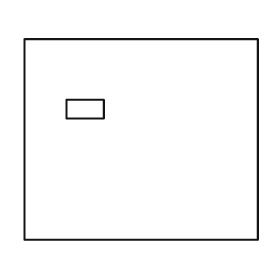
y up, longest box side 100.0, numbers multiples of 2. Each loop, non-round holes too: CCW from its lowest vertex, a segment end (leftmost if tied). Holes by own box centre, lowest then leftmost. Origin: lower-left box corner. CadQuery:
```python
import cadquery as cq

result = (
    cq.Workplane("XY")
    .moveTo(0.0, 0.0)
    .lineTo(100.0, 0.0)
    .lineTo(100.0, 86.0)
    .lineTo(0.0, 86.0)
    .close()
    .moveTo(18.0, 52.0)
    .lineTo(34.0, 52.0)
    .lineTo(34.0, 60.0)
    .lineTo(18.0, 60.0)
    .close()
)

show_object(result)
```